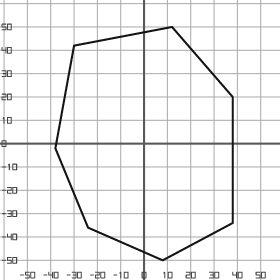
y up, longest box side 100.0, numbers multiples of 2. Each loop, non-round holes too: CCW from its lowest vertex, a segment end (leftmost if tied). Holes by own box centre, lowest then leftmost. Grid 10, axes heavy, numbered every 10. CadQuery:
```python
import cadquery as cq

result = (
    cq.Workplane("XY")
    .moveTo(8.0, -50.0)
    .lineTo(38.0, -34.0)
    .lineTo(38.0, 20.0)
    .lineTo(12.0, 50.0)
    .lineTo(-30.0, 42.0)
    .lineTo(-38.0, -2.0)
    .lineTo(-24.0, -36.0)
    .close()
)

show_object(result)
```